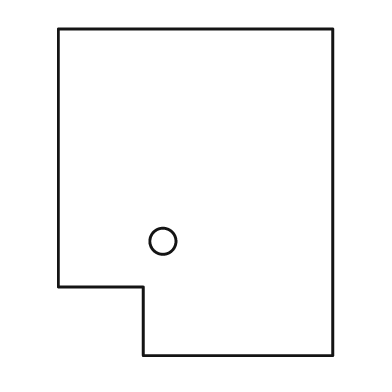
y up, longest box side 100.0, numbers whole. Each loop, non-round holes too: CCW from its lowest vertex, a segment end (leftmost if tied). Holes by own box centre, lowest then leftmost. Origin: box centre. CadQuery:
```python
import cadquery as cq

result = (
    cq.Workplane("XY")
    .moveTo(-16.0, -50.0)
    .lineTo(42.0, -50.0)
    .lineTo(42.0, 50.0)
    .lineTo(-42.0, 50.0)
    .lineTo(-42.0, -29.0)
    .lineTo(-16.0, -29.0)
    .close()
    .moveTo(-10.0, -15.0)
    .circle(4.0)
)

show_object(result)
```